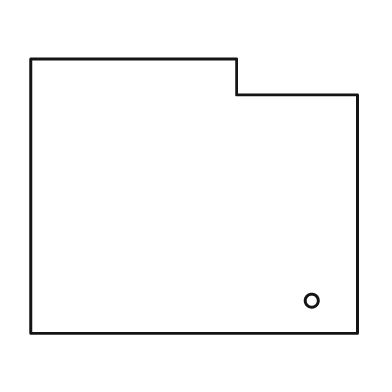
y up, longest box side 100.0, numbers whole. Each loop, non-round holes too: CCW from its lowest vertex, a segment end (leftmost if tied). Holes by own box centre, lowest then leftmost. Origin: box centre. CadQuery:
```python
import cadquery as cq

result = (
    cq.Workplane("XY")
    .moveTo(-50.0, -42.0)
    .lineTo(50.0, -42.0)
    .lineTo(50.0, 31.0)
    .lineTo(13.0, 31.0)
    .lineTo(13.0, 42.0)
    .lineTo(-50.0, 42.0)
    .close()
    .moveTo(36.0, -32.0)
    .circle(2.0)
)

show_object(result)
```